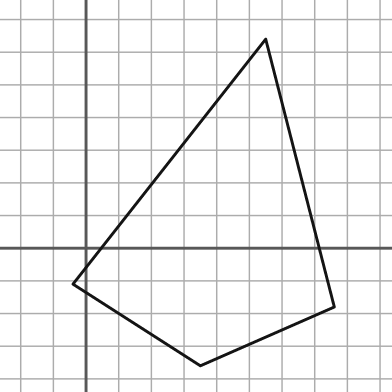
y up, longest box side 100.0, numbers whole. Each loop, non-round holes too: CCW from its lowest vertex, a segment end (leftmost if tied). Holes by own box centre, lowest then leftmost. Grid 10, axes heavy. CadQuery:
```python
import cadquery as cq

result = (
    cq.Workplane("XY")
    .moveTo(35.0, -36.0)
    .lineTo(76.0, -18.0)
    .lineTo(55.0, 64.0)
    .lineTo(-4.0, -11.0)
    .close()
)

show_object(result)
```